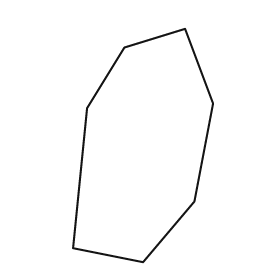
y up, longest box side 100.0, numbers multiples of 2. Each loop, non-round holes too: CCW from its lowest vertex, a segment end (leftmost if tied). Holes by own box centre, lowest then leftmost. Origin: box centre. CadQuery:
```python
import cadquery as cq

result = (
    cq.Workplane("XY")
    .moveTo(0.0, -50.0)
    .lineTo(22.0, -24.0)
    .lineTo(30.0, 18.0)
    .lineTo(18.0, 50.0)
    .lineTo(-8.0, 42.0)
    .lineTo(-24.0, 16.0)
    .lineTo(-30.0, -44.0)
    .close()
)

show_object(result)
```